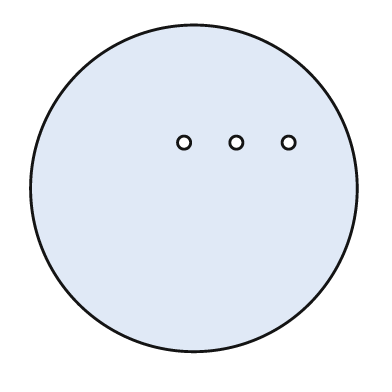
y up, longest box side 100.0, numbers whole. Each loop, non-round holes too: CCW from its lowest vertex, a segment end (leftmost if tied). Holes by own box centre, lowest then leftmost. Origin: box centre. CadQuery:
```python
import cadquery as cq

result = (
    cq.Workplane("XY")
    .moveTo(0.0, 0.0)
    .circle(50.0)
    .moveTo(-3.0, 14.0)
    .circle(2.0)
    .moveTo(13.0, 14.0)
    .circle(2.0)
    .moveTo(29.0, 14.0)
    .circle(2.0)
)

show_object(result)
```